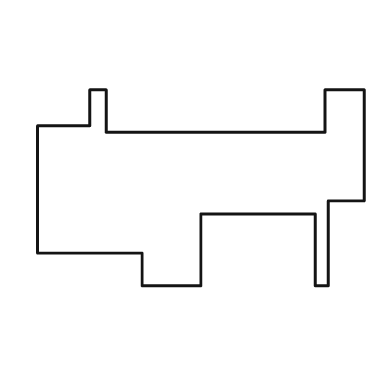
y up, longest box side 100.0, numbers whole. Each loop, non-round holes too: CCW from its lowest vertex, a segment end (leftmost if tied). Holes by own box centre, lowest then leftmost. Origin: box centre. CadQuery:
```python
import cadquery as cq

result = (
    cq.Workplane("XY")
    .moveTo(-18.0, -30.0)
    .lineTo(0.0, -30.0)
    .lineTo(0.0, -8.0)
    .lineTo(35.0, -8.0)
    .lineTo(35.0, -30.0)
    .lineTo(39.0, -30.0)
    .lineTo(39.0, -4.0)
    .lineTo(50.0, -4.0)
    .lineTo(50.0, 30.0)
    .lineTo(38.0, 30.0)
    .lineTo(38.0, 17.0)
    .lineTo(-29.0, 17.0)
    .lineTo(-29.0, 30.0)
    .lineTo(-34.0, 30.0)
    .lineTo(-34.0, 19.0)
    .lineTo(-50.0, 19.0)
    .lineTo(-50.0, -20.0)
    .lineTo(-18.0, -20.0)
    .close()
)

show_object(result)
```